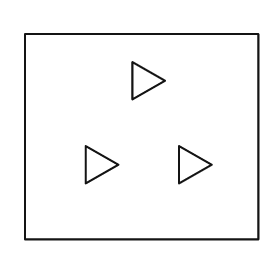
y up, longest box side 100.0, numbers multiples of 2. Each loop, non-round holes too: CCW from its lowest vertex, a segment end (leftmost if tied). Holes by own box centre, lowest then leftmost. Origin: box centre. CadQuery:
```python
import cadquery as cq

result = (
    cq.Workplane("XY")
    .moveTo(-50.0, -44.0)
    .lineTo(50.0, -44.0)
    .lineTo(50.0, 44.0)
    .lineTo(-50.0, 44.0)
    .close()
    .moveTo(-24.0, -20.0)
    .lineTo(-10.0, -12.0)
    .lineTo(-24.0, -4.0)
    .close()
    .moveTo(16.0, -20.0)
    .lineTo(30.0, -12.0)
    .lineTo(16.0, -4.0)
    .close()
    .moveTo(-4.0, 16.0)
    .lineTo(10.0, 24.0)
    .lineTo(-4.0, 32.0)
    .close()
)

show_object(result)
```